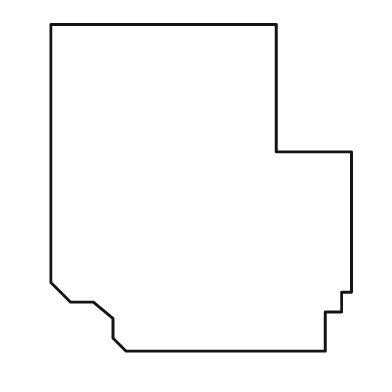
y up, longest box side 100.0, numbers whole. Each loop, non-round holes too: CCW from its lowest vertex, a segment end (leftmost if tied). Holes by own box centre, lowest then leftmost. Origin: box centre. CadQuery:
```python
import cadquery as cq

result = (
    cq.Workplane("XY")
    .moveTo(-23.0, -50.0)
    .lineTo(38.0, -50.0)
    .lineTo(38.0, -38.0)
    .lineTo(43.0, -38.0)
    .lineTo(43.0, -32.0)
    .lineTo(46.0, -32.0)
    .lineTo(46.0, 11.0)
    .lineTo(23.0, 11.0)
    .lineTo(23.0, 50.0)
    .lineTo(-46.0, 50.0)
    .lineTo(-46.0, -29.0)
    .lineTo(-40.0, -35.0)
    .lineTo(-33.0, -35.0)
    .lineTo(-27.0, -40.0)
    .lineTo(-27.0, -46.0)
    .close()
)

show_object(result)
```